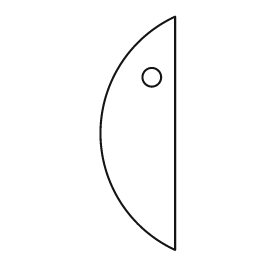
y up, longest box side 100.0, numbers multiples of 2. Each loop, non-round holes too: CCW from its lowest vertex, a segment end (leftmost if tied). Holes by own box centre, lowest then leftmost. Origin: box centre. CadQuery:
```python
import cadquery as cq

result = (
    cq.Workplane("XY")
    .moveTo(16.0, -50.0)
    .lineTo(16.0, 50.0)
    .threePointArc((-16.0, 0.0), (16.0, -50.0))
    .close()
    .moveTo(6.0, 24.0)
    .circle(4.0)
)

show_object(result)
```